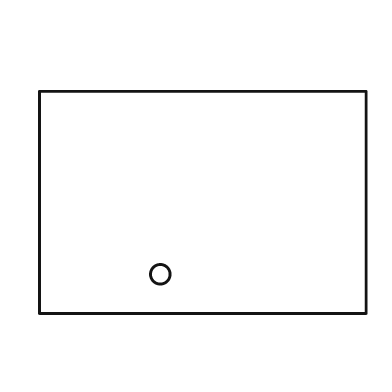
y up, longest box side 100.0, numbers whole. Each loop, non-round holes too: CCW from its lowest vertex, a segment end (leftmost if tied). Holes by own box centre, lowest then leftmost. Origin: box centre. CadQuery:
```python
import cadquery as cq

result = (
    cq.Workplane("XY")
    .moveTo(-50.0, -34.0)
    .lineTo(50.0, -34.0)
    .lineTo(50.0, 34.0)
    .lineTo(-50.0, 34.0)
    .close()
    .moveTo(-13.0, -22.0)
    .circle(3.0)
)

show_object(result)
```